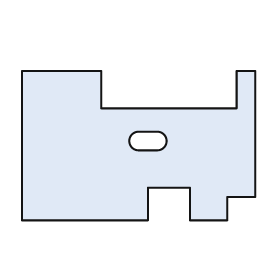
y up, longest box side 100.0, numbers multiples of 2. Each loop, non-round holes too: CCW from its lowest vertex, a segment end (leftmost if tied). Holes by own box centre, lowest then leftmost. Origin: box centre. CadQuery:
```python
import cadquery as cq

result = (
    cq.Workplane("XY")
    .moveTo(-50.0, -32.0)
    .lineTo(4.0, -32.0)
    .lineTo(4.0, -18.0)
    .lineTo(22.0, -18.0)
    .lineTo(22.0, -32.0)
    .lineTo(38.0, -32.0)
    .lineTo(38.0, -22.0)
    .lineTo(50.0, -22.0)
    .lineTo(50.0, 32.0)
    .lineTo(42.0, 32.0)
    .lineTo(42.0, 16.0)
    .lineTo(-16.0, 16.0)
    .lineTo(-16.0, 32.0)
    .lineTo(-50.0, 32.0)
    .close()
    .moveTo(0.0, -2.0)
    .lineTo(8.0, -2.0)
    .threePointArc((12.0, 2.0), (8.0, 6.0))
    .lineTo(0.0, 6.0)
    .threePointArc((-4.0, 2.0), (0.0, -2.0))
    .close()
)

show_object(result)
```